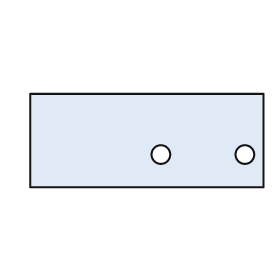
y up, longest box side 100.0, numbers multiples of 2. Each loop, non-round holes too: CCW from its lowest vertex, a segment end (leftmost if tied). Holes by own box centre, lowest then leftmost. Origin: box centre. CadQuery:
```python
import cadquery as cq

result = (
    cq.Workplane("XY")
    .moveTo(-50.0, -20.0)
    .lineTo(50.0, -20.0)
    .lineTo(50.0, 20.0)
    .lineTo(-50.0, 20.0)
    .close()
    .moveTo(6.0, -6.0)
    .circle(4.0)
    .moveTo(42.0, -6.0)
    .circle(4.0)
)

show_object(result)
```